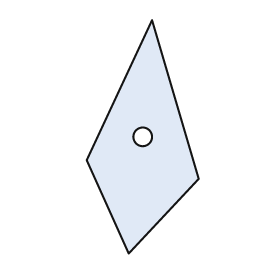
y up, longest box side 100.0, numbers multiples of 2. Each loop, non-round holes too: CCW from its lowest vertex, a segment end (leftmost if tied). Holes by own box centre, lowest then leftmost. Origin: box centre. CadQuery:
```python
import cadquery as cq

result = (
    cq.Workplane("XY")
    .moveTo(-6.0, -50.0)
    .lineTo(24.0, -18.0)
    .lineTo(4.0, 50.0)
    .lineTo(-24.0, -10.0)
    .close()
    .moveTo(0.0, 0.0)
    .circle(4.0)
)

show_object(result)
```